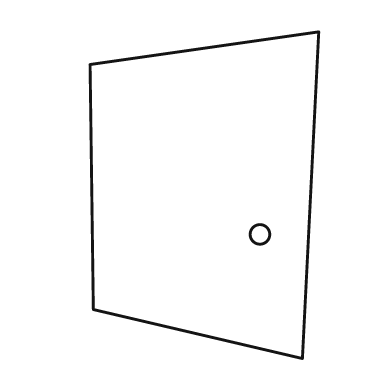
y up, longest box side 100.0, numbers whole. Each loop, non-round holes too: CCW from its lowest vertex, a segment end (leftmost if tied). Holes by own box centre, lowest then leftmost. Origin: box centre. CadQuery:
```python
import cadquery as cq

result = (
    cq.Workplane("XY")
    .moveTo(30.0, -50.0)
    .lineTo(35.0, 50.0)
    .lineTo(-35.0, 40.0)
    .lineTo(-34.0, -35.0)
    .close()
    .moveTo(17.0, -12.0)
    .circle(3.0)
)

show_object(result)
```